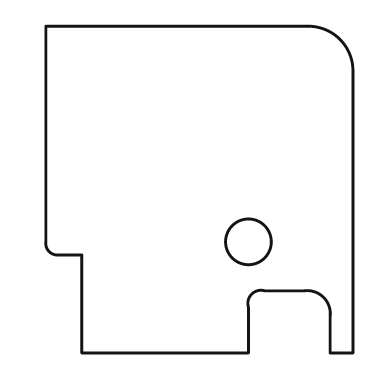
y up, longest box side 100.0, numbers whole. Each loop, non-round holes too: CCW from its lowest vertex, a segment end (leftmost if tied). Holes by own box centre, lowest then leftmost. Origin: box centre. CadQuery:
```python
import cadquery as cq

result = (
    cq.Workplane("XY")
    .moveTo(-36.0, -50.0)
    .lineTo(15.0, -50.0)
    .lineTo(15.0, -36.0)
    .threePointArc((16.0, -32.0), (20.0, -31.0))
    .lineTo(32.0, -31.0)
    .threePointArc((38.0, -33.0), (40.0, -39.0))
    .lineTo(40.0, -50.0)
    .lineTo(47.0, -50.0)
    .lineTo(47.0, 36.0)
    .threePointArc((43.0, 46.0), (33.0, 50.0))
    .lineTo(-47.0, 50.0)
    .lineTo(-47.0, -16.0)
    .threePointArc((-46.0, -19.0), (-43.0, -20.0))
    .lineTo(-36.0, -20.0)
    .close()
    .moveTo(15.0, -16.0)
    .circle(7.0)
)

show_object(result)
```